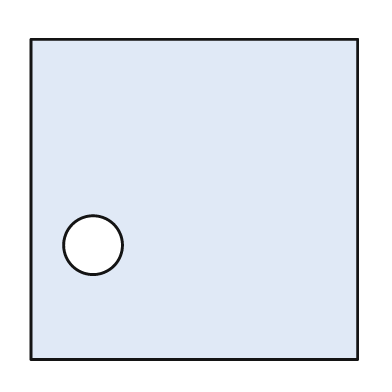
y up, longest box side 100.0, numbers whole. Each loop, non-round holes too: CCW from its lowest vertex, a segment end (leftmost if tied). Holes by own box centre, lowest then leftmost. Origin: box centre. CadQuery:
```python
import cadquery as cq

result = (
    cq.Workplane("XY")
    .moveTo(-50.0, -49.0)
    .lineTo(50.0, -49.0)
    .lineTo(50.0, 49.0)
    .lineTo(-50.0, 49.0)
    .close()
    .moveTo(-31.0, -14.0)
    .circle(9.0)
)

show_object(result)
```